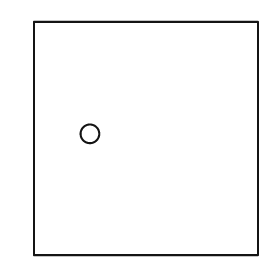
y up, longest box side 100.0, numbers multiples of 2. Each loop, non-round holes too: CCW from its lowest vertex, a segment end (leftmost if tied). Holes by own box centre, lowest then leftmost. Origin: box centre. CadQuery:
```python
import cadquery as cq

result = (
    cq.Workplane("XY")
    .moveTo(-48.0, -50.0)
    .lineTo(48.0, -50.0)
    .lineTo(48.0, 50.0)
    .lineTo(-48.0, 50.0)
    .close()
    .moveTo(-24.0, 2.0)
    .circle(4.0)
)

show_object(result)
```